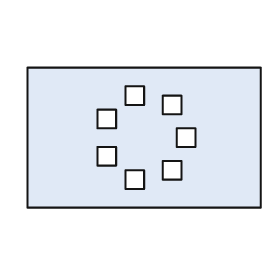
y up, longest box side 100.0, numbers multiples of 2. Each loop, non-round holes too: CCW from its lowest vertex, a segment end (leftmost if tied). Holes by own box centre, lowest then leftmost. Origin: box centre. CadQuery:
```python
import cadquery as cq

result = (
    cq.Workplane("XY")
    .moveTo(-50.0, -30.0)
    .lineTo(50.0, -30.0)
    .lineTo(50.0, 30.0)
    .lineTo(-50.0, 30.0)
    .close()
    .moveTo(-8.0, -22.0)
    .lineTo(0.0, -22.0)
    .lineTo(0.0, -14.0)
    .lineTo(-8.0, -14.0)
    .close()
    .moveTo(8.0, -18.0)
    .lineTo(16.0, -18.0)
    .lineTo(16.0, -10.0)
    .lineTo(8.0, -10.0)
    .close()
    .moveTo(-20.0, -12.0)
    .lineTo(-12.0, -12.0)
    .lineTo(-12.0, -4.0)
    .lineTo(-20.0, -4.0)
    .close()
    .moveTo(14.0, -4.0)
    .lineTo(22.0, -4.0)
    .lineTo(22.0, 4.0)
    .lineTo(14.0, 4.0)
    .close()
    .moveTo(-20.0, 4.0)
    .lineTo(-12.0, 4.0)
    .lineTo(-12.0, 12.0)
    .lineTo(-20.0, 12.0)
    .close()
    .moveTo(8.0, 10.0)
    .lineTo(16.0, 10.0)
    .lineTo(16.0, 18.0)
    .lineTo(8.0, 18.0)
    .close()
    .moveTo(-8.0, 14.0)
    .lineTo(0.0, 14.0)
    .lineTo(0.0, 22.0)
    .lineTo(-8.0, 22.0)
    .close()
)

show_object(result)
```